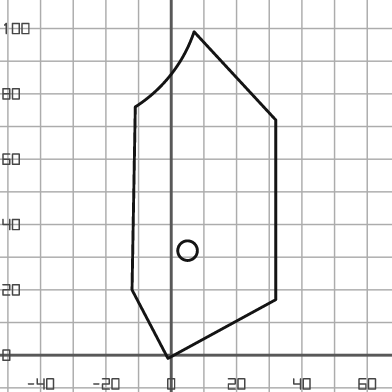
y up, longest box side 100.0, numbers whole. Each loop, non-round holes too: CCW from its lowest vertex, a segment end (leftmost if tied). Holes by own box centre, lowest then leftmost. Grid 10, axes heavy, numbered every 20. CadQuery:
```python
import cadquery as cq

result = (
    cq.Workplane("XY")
    .moveTo(-1.0, -1.0)
    .lineTo(32.0, 17.0)
    .lineTo(32.0, 72.0)
    .lineTo(7.0, 99.0)
    .threePointArc((0.0, 86.0), (-11.0, 76.0))
    .lineTo(-12.0, 20.0)
    .close()
    .moveTo(5.0, 32.0)
    .circle(3.0)
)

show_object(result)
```